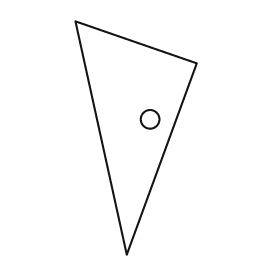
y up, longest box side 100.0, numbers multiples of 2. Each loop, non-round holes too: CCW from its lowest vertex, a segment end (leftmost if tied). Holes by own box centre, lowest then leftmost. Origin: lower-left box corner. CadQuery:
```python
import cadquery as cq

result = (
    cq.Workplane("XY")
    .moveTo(22.0, 0.0)
    .lineTo(52.0, 82.0)
    .lineTo(0.0, 100.0)
    .close()
    .moveTo(32.0, 58.0)
    .circle(4.0)
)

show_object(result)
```